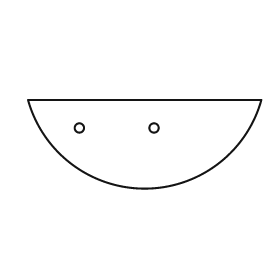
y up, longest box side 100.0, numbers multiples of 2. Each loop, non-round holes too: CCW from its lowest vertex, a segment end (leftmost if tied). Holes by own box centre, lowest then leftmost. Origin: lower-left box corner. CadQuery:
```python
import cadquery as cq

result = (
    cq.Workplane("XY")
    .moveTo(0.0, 38.0)
    .threePointArc((50.0, 0.0), (100.0, 38.0))
    .close()
    .moveTo(22.0, 26.0)
    .circle(2.0)
    .moveTo(54.0, 26.0)
    .circle(2.0)
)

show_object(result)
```